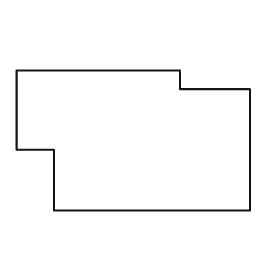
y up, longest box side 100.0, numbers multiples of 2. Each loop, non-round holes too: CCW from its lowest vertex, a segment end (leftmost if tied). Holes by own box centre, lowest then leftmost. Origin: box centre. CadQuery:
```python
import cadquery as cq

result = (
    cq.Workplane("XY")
    .moveTo(-34.0, -30.0)
    .lineTo(50.0, -30.0)
    .lineTo(50.0, 22.0)
    .lineTo(20.0, 22.0)
    .lineTo(20.0, 30.0)
    .lineTo(-50.0, 30.0)
    .lineTo(-50.0, -4.0)
    .lineTo(-34.0, -4.0)
    .close()
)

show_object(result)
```